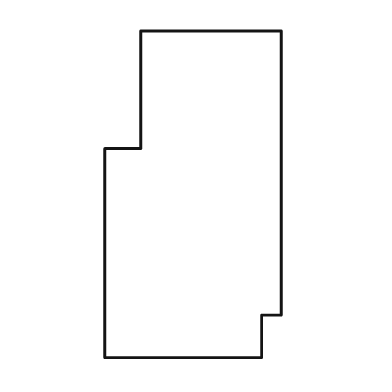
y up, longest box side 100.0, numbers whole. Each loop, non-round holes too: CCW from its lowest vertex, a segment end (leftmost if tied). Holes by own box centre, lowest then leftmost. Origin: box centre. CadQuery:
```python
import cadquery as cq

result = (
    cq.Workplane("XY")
    .moveTo(-27.0, -50.0)
    .lineTo(21.0, -50.0)
    .lineTo(21.0, -37.0)
    .lineTo(27.0, -37.0)
    .lineTo(27.0, 50.0)
    .lineTo(-16.0, 50.0)
    .lineTo(-16.0, 14.0)
    .lineTo(-27.0, 14.0)
    .close()
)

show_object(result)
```